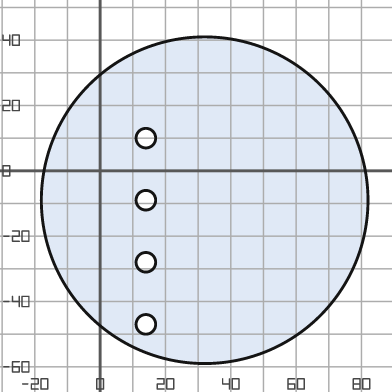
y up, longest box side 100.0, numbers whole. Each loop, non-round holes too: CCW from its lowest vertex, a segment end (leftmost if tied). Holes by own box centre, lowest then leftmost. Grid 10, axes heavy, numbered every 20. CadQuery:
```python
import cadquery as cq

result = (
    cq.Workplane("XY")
    .moveTo(32.0, -9.0)
    .circle(50.0)
    .moveTo(14.0, -47.0)
    .circle(3.0)
    .moveTo(14.0, -28.0)
    .circle(3.0)
    .moveTo(14.0, -9.0)
    .circle(3.0)
    .moveTo(14.0, 10.0)
    .circle(3.0)
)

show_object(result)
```